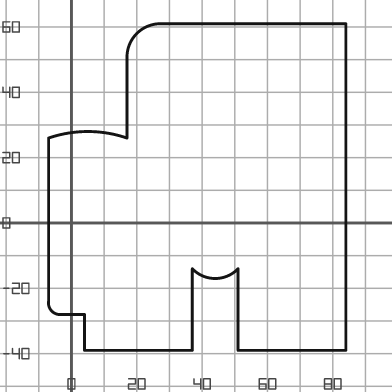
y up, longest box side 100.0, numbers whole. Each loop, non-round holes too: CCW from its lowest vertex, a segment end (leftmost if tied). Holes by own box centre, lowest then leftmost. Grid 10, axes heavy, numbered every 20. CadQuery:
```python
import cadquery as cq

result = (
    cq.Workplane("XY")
    .moveTo(4.0, -39.0)
    .lineTo(37.0, -39.0)
    .lineTo(37.0, -14.0)
    .threePointArc((44.0, -17.0), (51.0, -14.0))
    .lineTo(51.0, -39.0)
    .lineTo(84.0, -39.0)
    .lineTo(84.0, 61.0)
    .lineTo(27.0, 61.0)
    .threePointArc((20.0, 58.0), (17.0, 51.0))
    .lineTo(17.0, 26.0)
    .threePointArc((5.0, 28.0), (-7.0, 26.0))
    .lineTo(-7.0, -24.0)
    .threePointArc((-6.0, -27.0), (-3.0, -28.0))
    .lineTo(4.0, -28.0)
    .close()
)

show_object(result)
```